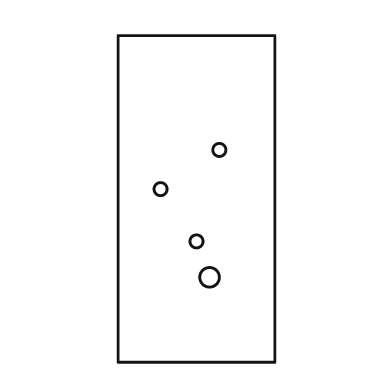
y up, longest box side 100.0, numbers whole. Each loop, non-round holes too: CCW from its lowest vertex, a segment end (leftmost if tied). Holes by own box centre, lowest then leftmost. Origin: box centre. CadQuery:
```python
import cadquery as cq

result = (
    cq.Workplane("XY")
    .moveTo(-24.0, -50.0)
    .lineTo(24.0, -50.0)
    .lineTo(24.0, 50.0)
    .lineTo(-24.0, 50.0)
    .close()
    .moveTo(4.0, -24.0)
    .circle(3.0)
    .moveTo(0.0, -13.0)
    .circle(2.0)
    .moveTo(-11.0, 3.0)
    .circle(2.0)
    .moveTo(7.0, 15.0)
    .circle(2.0)
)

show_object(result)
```